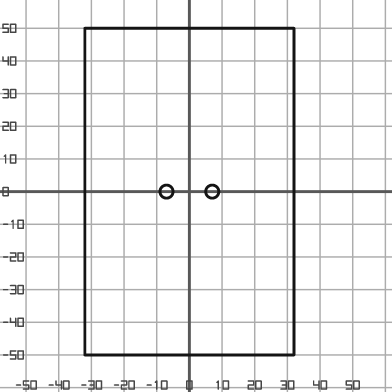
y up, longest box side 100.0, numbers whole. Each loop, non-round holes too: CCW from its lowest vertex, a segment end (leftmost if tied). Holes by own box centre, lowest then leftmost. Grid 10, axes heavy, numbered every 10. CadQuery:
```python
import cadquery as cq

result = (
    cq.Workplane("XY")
    .moveTo(-32.0, -50.0)
    .lineTo(32.0, -50.0)
    .lineTo(32.0, 50.0)
    .lineTo(-32.0, 50.0)
    .close()
    .moveTo(-7.0, 0.0)
    .circle(2.0)
    .moveTo(7.0, 0.0)
    .circle(2.0)
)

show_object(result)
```